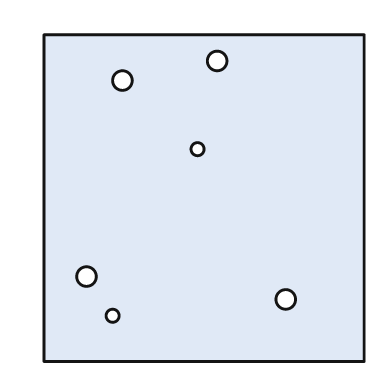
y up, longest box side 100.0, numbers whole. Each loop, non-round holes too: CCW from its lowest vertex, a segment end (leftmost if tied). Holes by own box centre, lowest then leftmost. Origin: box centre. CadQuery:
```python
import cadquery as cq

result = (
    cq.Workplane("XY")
    .moveTo(-49.0, -50.0)
    .lineTo(49.0, -50.0)
    .lineTo(49.0, 50.0)
    .lineTo(-49.0, 50.0)
    .close()
    .moveTo(-28.0, -36.0)
    .circle(2.0)
    .moveTo(25.0, -31.0)
    .circle(3.0)
    .moveTo(-36.0, -24.0)
    .circle(3.0)
    .moveTo(-2.0, 15.0)
    .circle(2.0)
    .moveTo(-25.0, 36.0)
    .circle(3.0)
    .moveTo(4.0, 42.0)
    .circle(3.0)
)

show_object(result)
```